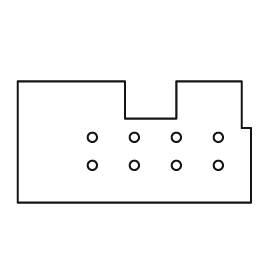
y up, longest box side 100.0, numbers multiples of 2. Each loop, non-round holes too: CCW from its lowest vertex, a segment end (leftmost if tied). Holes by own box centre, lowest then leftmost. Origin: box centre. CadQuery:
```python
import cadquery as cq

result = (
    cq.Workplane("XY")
    .moveTo(-50.0, -26.0)
    .lineTo(50.0, -26.0)
    .lineTo(50.0, 6.0)
    .lineTo(46.0, 6.0)
    .lineTo(46.0, 26.0)
    .lineTo(18.0, 26.0)
    .lineTo(18.0, 10.0)
    .lineTo(-4.0, 10.0)
    .lineTo(-4.0, 26.0)
    .lineTo(-50.0, 26.0)
    .close()
    .moveTo(-18.0, -10.0)
    .circle(2.0)
    .moveTo(0.0, -10.0)
    .circle(2.0)
    .moveTo(18.0, -10.0)
    .circle(2.0)
    .moveTo(36.0, -10.0)
    .circle(2.0)
    .moveTo(-18.0, 2.0)
    .circle(2.0)
    .moveTo(0.0, 2.0)
    .circle(2.0)
    .moveTo(18.0, 2.0)
    .circle(2.0)
    .moveTo(36.0, 2.0)
    .circle(2.0)
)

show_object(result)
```